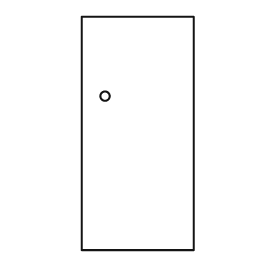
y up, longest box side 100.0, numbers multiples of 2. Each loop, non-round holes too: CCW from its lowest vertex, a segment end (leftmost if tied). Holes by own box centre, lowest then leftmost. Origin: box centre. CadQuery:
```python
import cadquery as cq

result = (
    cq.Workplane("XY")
    .moveTo(-24.0, -50.0)
    .lineTo(24.0, -50.0)
    .lineTo(24.0, 50.0)
    .lineTo(-24.0, 50.0)
    .close()
    .moveTo(-14.0, 16.0)
    .circle(2.0)
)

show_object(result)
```